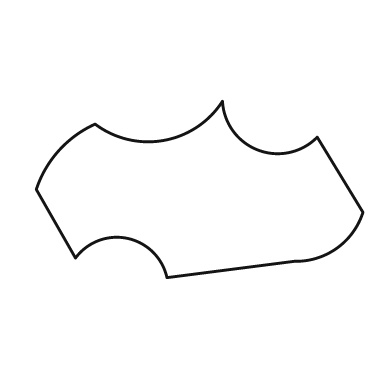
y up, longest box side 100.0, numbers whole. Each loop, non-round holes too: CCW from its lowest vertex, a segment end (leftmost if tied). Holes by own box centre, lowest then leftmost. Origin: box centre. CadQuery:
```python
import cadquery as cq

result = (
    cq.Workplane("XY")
    .moveTo(-10.0, -27.0)
    .lineTo(29.0, -22.0)
    .threePointArc((42.0, -18.0), (50.0, -7.0))
    .lineTo(36.0, 16.0)
    .threePointArc((18.0, 12.0), (7.0, 27.0))
    .threePointArc((-11.0, 15.0), (-32.0, 20.0))
    .threePointArc((-43.0, 12.0), (-50.0, 0.0))
    .lineTo(-38.0, -21.0)
    .threePointArc((-22.0, -15.0), (-10.0, -27.0))
    .close()
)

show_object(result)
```